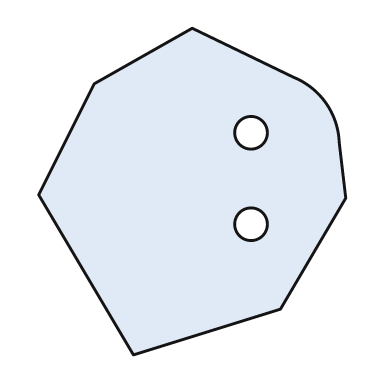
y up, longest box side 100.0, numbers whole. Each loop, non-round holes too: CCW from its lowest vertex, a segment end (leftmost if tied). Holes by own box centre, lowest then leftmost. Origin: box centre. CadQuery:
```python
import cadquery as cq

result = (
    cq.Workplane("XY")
    .moveTo(-18.0, -50.0)
    .lineTo(27.0, -36.0)
    .lineTo(47.0, -2.0)
    .lineTo(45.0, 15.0)
    .threePointArc((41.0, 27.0), (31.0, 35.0))
    .lineTo(0.0, 50.0)
    .lineTo(-30.0, 33.0)
    .lineTo(-47.0, -1.0)
    .close()
    .moveTo(18.0, -10.0)
    .circle(5.0)
    .moveTo(18.0, 18.0)
    .circle(5.0)
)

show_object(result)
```